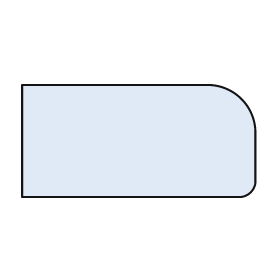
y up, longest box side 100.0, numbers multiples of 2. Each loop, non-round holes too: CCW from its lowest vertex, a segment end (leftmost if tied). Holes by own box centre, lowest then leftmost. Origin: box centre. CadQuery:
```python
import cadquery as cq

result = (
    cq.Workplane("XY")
    .moveTo(-50.0, -24.0)
    .lineTo(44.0, -24.0)
    .threePointArc((48.0, -22.0), (50.0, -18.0))
    .lineTo(50.0, 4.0)
    .threePointArc((44.0, 18.0), (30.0, 24.0))
    .lineTo(-50.0, 24.0)
    .close()
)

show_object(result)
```